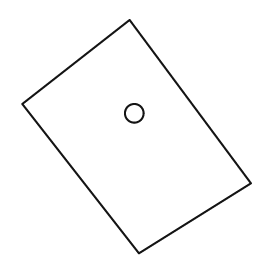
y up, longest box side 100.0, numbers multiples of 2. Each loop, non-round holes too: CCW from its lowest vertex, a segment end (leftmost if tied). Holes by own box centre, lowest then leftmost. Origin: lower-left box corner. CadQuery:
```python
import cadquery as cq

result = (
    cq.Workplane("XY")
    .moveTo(50.0, 0.0)
    .lineTo(98.0, 30.0)
    .lineTo(46.0, 100.0)
    .lineTo(0.0, 64.0)
    .close()
    .moveTo(48.0, 60.0)
    .circle(4.0)
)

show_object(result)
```